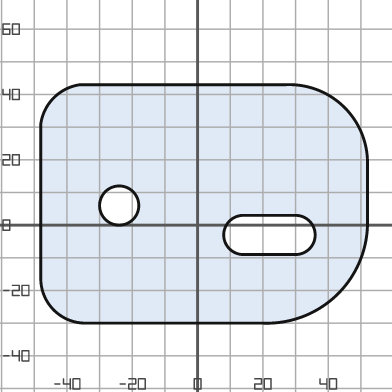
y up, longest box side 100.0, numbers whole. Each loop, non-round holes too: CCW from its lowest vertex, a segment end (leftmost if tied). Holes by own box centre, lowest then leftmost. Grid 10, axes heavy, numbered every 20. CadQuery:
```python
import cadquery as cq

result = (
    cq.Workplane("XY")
    .moveTo(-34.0, -30.0)
    .lineTo(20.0, -30.0)
    .threePointArc((43.0, -21.0), (52.0, 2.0))
    .lineTo(52.0, 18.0)
    .threePointArc((45.0, 36.0), (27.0, 43.0))
    .lineTo(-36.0, 43.0)
    .threePointArc((-44.0, 39.0), (-48.0, 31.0))
    .lineTo(-48.0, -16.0)
    .threePointArc((-44.0, -26.0), (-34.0, -30.0))
    .close()
    .moveTo(14.0, -9.0)
    .lineTo(30.0, -9.0)
    .threePointArc((36.0, -3.0), (30.0, 3.0))
    .lineTo(14.0, 3.0)
    .threePointArc((8.0, -3.0), (14.0, -9.0))
    .close()
    .moveTo(-24.0, 6.0)
    .circle(6.0)
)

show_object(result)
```